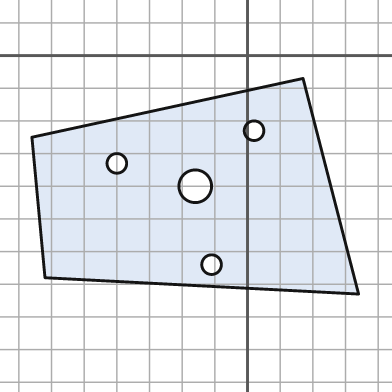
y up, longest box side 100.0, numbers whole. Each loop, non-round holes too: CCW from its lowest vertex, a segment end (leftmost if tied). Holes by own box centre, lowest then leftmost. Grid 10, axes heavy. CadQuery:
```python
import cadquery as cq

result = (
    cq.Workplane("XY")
    .moveTo(34.0, -73.0)
    .lineTo(17.0, -7.0)
    .lineTo(-66.0, -25.0)
    .lineTo(-62.0, -68.0)
    .close()
    .moveTo(-11.0, -64.0)
    .circle(3.0)
    .moveTo(-16.0, -40.0)
    .circle(5.0)
    .moveTo(-40.0, -33.0)
    .circle(3.0)
    .moveTo(2.0, -23.0)
    .circle(3.0)
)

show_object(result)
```